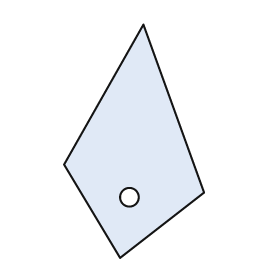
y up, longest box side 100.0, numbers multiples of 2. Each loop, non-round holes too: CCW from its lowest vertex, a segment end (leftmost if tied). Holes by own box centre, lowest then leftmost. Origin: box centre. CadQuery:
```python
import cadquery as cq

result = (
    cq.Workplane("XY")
    .moveTo(-6.0, -50.0)
    .lineTo(30.0, -22.0)
    .lineTo(4.0, 50.0)
    .lineTo(-30.0, -10.0)
    .close()
    .moveTo(-2.0, -24.0)
    .circle(4.0)
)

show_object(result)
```